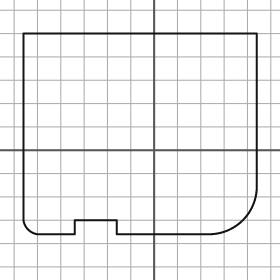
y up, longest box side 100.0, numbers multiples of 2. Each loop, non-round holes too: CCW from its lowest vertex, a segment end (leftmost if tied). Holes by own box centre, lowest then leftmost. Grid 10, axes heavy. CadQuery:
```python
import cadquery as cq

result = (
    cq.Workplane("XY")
    .moveTo(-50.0, -36.0)
    .lineTo(-34.0, -36.0)
    .lineTo(-34.0, -30.0)
    .lineTo(-16.0, -30.0)
    .lineTo(-16.0, -36.0)
    .lineTo(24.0, -36.0)
    .threePointArc((38.0, -30.0), (44.0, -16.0))
    .lineTo(44.0, 50.0)
    .lineTo(-56.0, 50.0)
    .lineTo(-56.0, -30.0)
    .threePointArc((-54.0, -34.0), (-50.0, -36.0))
    .close()
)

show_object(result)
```